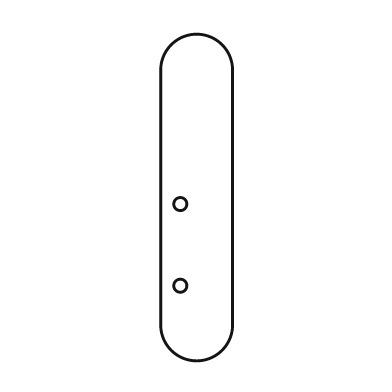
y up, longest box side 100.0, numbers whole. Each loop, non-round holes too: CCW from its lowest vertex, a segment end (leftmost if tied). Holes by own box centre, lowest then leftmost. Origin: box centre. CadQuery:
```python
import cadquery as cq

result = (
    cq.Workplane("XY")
    .moveTo(-11.0, -39.0)
    .threePointArc((0.0, -50.0), (11.0, -39.0))
    .lineTo(11.0, 39.0)
    .threePointArc((0.0, 50.0), (-11.0, 39.0))
    .close()
    .moveTo(-5.0, -27.0)
    .circle(2.0)
    .moveTo(-5.0, -2.0)
    .circle(2.0)
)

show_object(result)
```